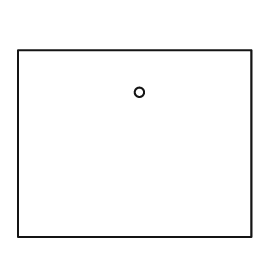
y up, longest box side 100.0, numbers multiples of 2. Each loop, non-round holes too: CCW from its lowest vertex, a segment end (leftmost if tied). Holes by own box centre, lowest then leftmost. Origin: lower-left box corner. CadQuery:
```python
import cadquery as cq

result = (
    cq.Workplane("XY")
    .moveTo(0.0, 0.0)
    .lineTo(100.0, 0.0)
    .lineTo(100.0, 80.0)
    .lineTo(0.0, 80.0)
    .close()
    .moveTo(52.0, 62.0)
    .circle(2.0)
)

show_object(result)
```